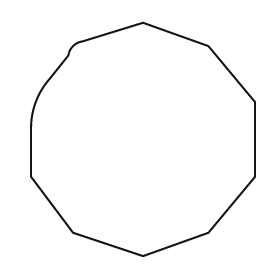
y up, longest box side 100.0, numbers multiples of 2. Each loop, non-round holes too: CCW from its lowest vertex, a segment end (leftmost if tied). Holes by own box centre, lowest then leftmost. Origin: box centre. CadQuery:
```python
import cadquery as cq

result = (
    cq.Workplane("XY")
    .moveTo(0.0, -50.0)
    .lineTo(28.0, -40.0)
    .lineTo(48.0, -16.0)
    .lineTo(48.0, 16.0)
    .lineTo(28.0, 40.0)
    .lineTo(0.0, 50.0)
    .lineTo(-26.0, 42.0)
    .threePointArc((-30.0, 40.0), (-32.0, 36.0))
    .lineTo(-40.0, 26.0)
    .threePointArc((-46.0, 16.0), (-48.0, 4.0))
    .lineTo(-48.0, -16.0)
    .lineTo(-30.0, -40.0)
    .close()
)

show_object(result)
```